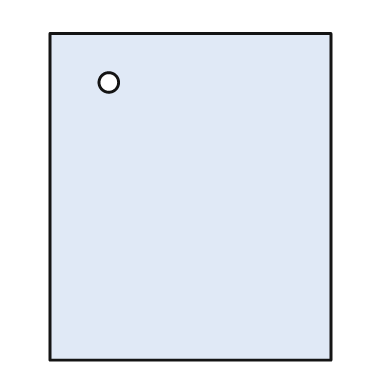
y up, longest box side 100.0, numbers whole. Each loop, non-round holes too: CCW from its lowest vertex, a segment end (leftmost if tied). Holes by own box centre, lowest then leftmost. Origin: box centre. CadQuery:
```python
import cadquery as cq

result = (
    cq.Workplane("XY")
    .moveTo(-43.0, -50.0)
    .lineTo(43.0, -50.0)
    .lineTo(43.0, 50.0)
    .lineTo(-43.0, 50.0)
    .close()
    .moveTo(-25.0, 35.0)
    .circle(3.0)
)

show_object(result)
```